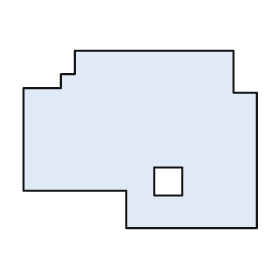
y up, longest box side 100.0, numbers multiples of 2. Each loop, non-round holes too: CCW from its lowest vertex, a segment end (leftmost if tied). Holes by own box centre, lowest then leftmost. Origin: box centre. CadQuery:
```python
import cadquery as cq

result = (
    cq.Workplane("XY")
    .moveTo(-6.0, -38.0)
    .lineTo(50.0, -38.0)
    .lineTo(50.0, 20.0)
    .lineTo(40.0, 20.0)
    .lineTo(40.0, 38.0)
    .lineTo(-28.0, 38.0)
    .lineTo(-28.0, 28.0)
    .lineTo(-34.0, 28.0)
    .lineTo(-34.0, 22.0)
    .lineTo(-50.0, 22.0)
    .lineTo(-50.0, -22.0)
    .lineTo(-6.0, -22.0)
    .close()
    .moveTo(6.0, -24.0)
    .lineTo(18.0, -24.0)
    .lineTo(18.0, -12.0)
    .lineTo(6.0, -12.0)
    .close()
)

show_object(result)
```